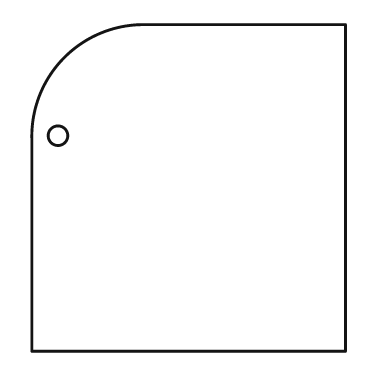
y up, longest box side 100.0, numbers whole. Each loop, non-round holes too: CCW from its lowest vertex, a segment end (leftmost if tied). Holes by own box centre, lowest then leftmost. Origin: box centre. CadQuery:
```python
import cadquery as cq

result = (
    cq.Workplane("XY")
    .moveTo(-48.0, -50.0)
    .lineTo(48.0, -50.0)
    .lineTo(48.0, 50.0)
    .lineTo(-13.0, 50.0)
    .threePointArc((-38.0, 40.0), (-48.0, 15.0))
    .close()
    .moveTo(-40.0, 16.0)
    .circle(3.0)
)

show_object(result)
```